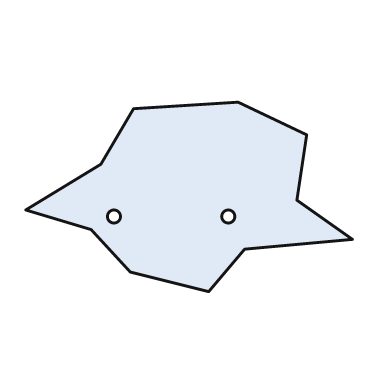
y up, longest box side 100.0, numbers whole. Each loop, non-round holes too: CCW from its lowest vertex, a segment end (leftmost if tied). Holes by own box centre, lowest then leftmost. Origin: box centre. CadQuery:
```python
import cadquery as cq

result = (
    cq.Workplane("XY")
    .moveTo(6.0, -29.0)
    .lineTo(17.0, -16.0)
    .lineTo(50.0, -13.0)
    .lineTo(33.0, -1.0)
    .lineTo(36.0, 19.0)
    .lineTo(15.0, 29.0)
    .lineTo(-17.0, 27.0)
    .lineTo(-27.0, 10.0)
    .lineTo(-50.0, -4.0)
    .lineTo(-30.0, -10.0)
    .lineTo(-18.0, -23.0)
    .close()
    .moveTo(-23.0, -6.0)
    .circle(2.0)
    .moveTo(12.0, -6.0)
    .circle(2.0)
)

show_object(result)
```